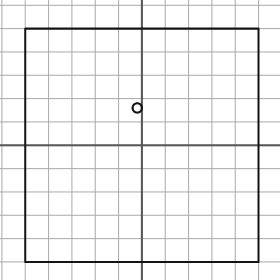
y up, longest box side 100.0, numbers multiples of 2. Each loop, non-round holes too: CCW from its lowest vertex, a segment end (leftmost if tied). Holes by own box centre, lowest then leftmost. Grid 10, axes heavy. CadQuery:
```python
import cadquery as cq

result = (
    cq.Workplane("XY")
    .moveTo(-50.0, -50.0)
    .lineTo(50.0, -50.0)
    .lineTo(50.0, 50.0)
    .lineTo(-50.0, 50.0)
    .close()
    .moveTo(-2.0, 16.0)
    .circle(2.0)
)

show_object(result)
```